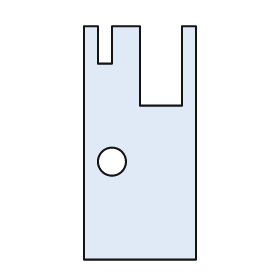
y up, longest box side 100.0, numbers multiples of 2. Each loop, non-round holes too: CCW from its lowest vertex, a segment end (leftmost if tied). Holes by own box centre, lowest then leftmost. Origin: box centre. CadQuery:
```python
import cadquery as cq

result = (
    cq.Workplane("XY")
    .moveTo(-24.0, -50.0)
    .lineTo(24.0, -50.0)
    .lineTo(24.0, 50.0)
    .lineTo(18.0, 50.0)
    .lineTo(18.0, 16.0)
    .lineTo(0.0, 16.0)
    .lineTo(0.0, 50.0)
    .lineTo(-12.0, 50.0)
    .lineTo(-12.0, 34.0)
    .lineTo(-18.0, 34.0)
    .lineTo(-18.0, 50.0)
    .lineTo(-24.0, 50.0)
    .close()
    .moveTo(-12.0, -8.0)
    .circle(6.0)
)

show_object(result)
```